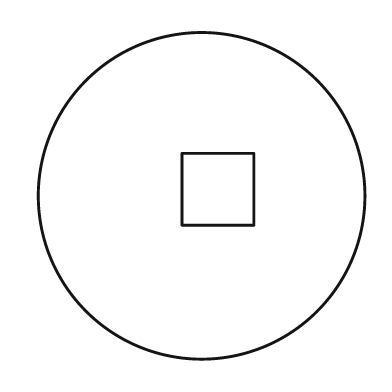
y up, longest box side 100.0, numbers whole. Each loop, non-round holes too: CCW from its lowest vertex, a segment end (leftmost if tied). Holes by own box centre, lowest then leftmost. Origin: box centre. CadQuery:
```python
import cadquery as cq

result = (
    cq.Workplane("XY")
    .moveTo(0.0, 0.0)
    .circle(50.0)
    .moveTo(-6.0, -9.0)
    .lineTo(16.0, -9.0)
    .lineTo(16.0, 13.0)
    .lineTo(-6.0, 13.0)
    .close()
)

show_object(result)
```